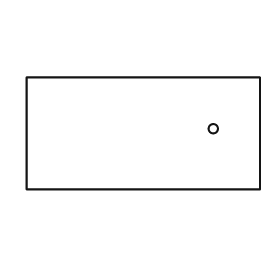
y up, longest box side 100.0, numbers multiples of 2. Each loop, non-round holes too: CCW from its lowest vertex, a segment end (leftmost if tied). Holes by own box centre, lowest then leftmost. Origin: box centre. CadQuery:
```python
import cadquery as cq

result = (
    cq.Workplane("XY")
    .moveTo(-50.0, -24.0)
    .lineTo(50.0, -24.0)
    .lineTo(50.0, 24.0)
    .lineTo(-50.0, 24.0)
    .close()
    .moveTo(30.0, 2.0)
    .circle(2.0)
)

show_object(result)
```